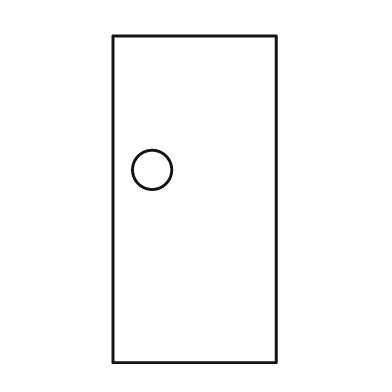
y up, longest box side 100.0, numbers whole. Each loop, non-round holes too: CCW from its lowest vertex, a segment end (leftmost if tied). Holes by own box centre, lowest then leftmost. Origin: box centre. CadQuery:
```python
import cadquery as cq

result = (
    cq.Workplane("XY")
    .moveTo(-25.0, -50.0)
    .lineTo(25.0, -50.0)
    .lineTo(25.0, 50.0)
    .lineTo(-25.0, 50.0)
    .close()
    .moveTo(-13.0, 9.0)
    .circle(6.0)
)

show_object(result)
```